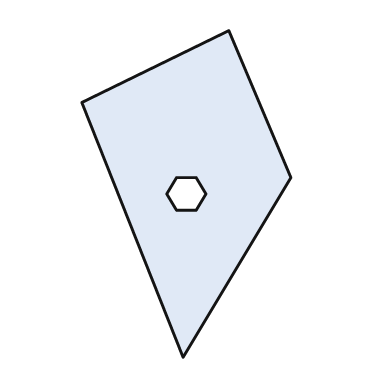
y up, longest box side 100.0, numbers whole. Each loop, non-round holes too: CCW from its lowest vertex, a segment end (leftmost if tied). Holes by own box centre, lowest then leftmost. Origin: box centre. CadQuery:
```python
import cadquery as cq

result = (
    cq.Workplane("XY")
    .moveTo(-1.0, -50.0)
    .lineTo(32.0, 5.0)
    .lineTo(13.0, 50.0)
    .lineTo(-32.0, 28.0)
    .close()
    .moveTo(-3.0, -5.0)
    .lineTo(3.0, -5.0)
    .lineTo(6.0, 0.0)
    .lineTo(3.0, 5.0)
    .lineTo(-3.0, 5.0)
    .lineTo(-6.0, 0.0)
    .close()
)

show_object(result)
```